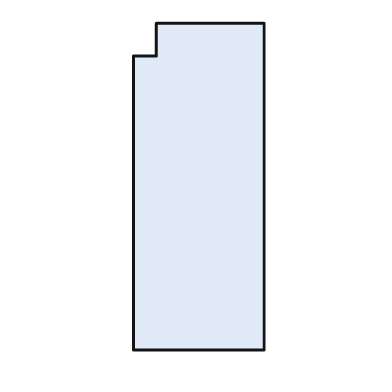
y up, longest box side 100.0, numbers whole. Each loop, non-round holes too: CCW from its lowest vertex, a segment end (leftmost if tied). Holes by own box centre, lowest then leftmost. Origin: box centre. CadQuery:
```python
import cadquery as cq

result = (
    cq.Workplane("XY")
    .moveTo(-20.0, -50.0)
    .lineTo(20.0, -50.0)
    .lineTo(20.0, 50.0)
    .lineTo(-13.0, 50.0)
    .lineTo(-13.0, 40.0)
    .lineTo(-20.0, 40.0)
    .close()
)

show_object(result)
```